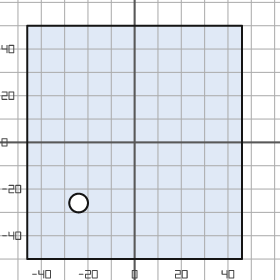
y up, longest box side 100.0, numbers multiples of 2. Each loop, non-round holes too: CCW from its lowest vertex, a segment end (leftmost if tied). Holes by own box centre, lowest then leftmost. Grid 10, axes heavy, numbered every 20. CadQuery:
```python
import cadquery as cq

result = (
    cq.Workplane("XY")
    .moveTo(-46.0, -50.0)
    .lineTo(46.0, -50.0)
    .lineTo(46.0, 50.0)
    .lineTo(-46.0, 50.0)
    .close()
    .moveTo(-24.0, -26.0)
    .circle(4.0)
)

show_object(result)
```